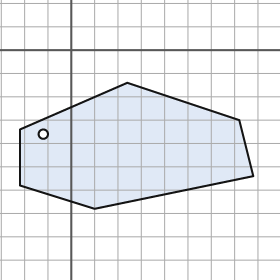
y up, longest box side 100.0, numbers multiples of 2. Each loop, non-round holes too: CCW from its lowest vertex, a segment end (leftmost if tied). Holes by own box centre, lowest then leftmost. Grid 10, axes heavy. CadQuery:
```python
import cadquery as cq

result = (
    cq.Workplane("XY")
    .moveTo(10.0, -68.0)
    .lineTo(78.0, -54.0)
    .lineTo(72.0, -30.0)
    .lineTo(24.0, -14.0)
    .lineTo(-22.0, -34.0)
    .lineTo(-22.0, -58.0)
    .close()
    .moveTo(-12.0, -36.0)
    .circle(2.0)
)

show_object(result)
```